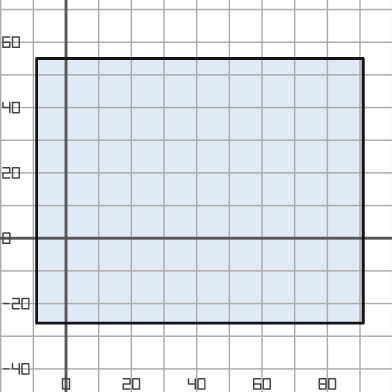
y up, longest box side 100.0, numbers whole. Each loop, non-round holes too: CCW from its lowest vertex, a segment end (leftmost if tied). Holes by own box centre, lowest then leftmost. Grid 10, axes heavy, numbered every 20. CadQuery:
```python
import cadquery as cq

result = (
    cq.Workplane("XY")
    .moveTo(-9.0, -26.0)
    .lineTo(91.0, -26.0)
    .lineTo(91.0, 55.0)
    .lineTo(-9.0, 55.0)
    .close()
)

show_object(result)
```